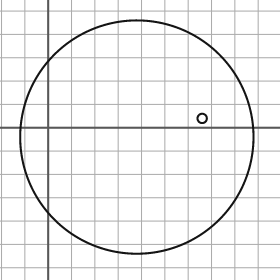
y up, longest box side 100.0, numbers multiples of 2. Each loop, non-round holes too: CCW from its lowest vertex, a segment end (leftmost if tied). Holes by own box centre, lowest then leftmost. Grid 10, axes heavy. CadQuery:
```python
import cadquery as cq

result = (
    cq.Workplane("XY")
    .moveTo(38.0, -4.0)
    .circle(50.0)
    .moveTo(66.0, 4.0)
    .circle(2.0)
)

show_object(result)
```